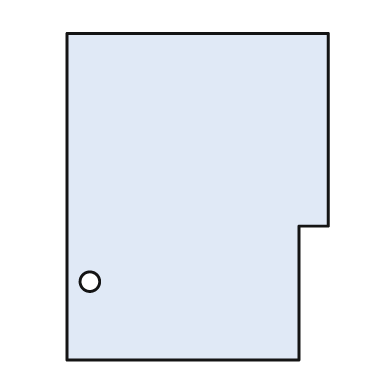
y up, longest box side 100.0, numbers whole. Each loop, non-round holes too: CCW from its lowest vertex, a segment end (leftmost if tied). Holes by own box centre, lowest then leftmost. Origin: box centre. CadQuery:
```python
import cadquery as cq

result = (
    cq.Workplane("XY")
    .moveTo(-40.0, -50.0)
    .lineTo(31.0, -50.0)
    .lineTo(31.0, -9.0)
    .lineTo(40.0, -9.0)
    .lineTo(40.0, 50.0)
    .lineTo(-40.0, 50.0)
    .close()
    .moveTo(-33.0, -26.0)
    .circle(3.0)
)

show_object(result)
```